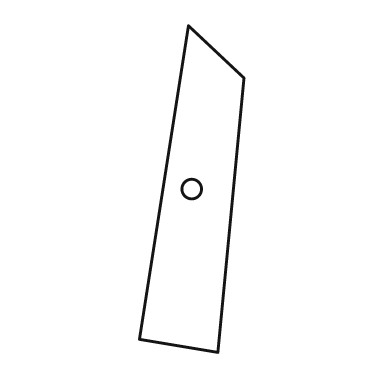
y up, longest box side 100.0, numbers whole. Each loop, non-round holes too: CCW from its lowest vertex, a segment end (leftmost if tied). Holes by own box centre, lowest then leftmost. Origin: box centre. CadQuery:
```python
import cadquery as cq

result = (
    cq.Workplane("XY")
    .moveTo(8.0, -50.0)
    .lineTo(16.0, 34.0)
    .lineTo(-1.0, 50.0)
    .lineTo(-16.0, -46.0)
    .close()
    .moveTo(0.0, 0.0)
    .circle(3.0)
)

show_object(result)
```